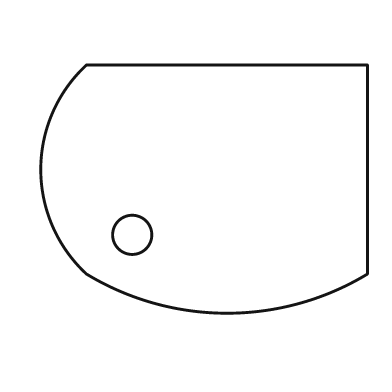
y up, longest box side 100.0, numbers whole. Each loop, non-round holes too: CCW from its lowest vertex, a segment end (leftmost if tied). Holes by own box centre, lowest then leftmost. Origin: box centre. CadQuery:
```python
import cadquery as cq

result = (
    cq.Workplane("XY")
    .moveTo(-36.0, -26.0)
    .threePointArc((7.0, -38.0), (50.0, -26.0))
    .lineTo(50.0, 38.0)
    .lineTo(-36.0, 38.0)
    .threePointArc((-50.0, 6.0), (-36.0, -26.0))
    .close()
    .moveTo(-22.0, -14.0)
    .circle(6.0)
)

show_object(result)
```